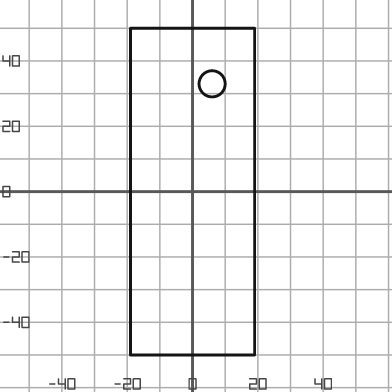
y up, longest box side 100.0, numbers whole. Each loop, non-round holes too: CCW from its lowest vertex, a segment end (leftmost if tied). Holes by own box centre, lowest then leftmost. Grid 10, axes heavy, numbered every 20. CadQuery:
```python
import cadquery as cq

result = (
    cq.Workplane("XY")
    .moveTo(-19.0, -50.0)
    .lineTo(19.0, -50.0)
    .lineTo(19.0, 50.0)
    .lineTo(-19.0, 50.0)
    .close()
    .moveTo(6.0, 33.0)
    .circle(4.0)
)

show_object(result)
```